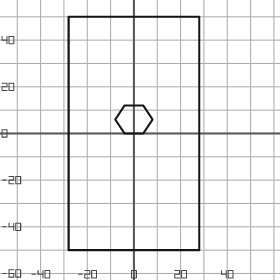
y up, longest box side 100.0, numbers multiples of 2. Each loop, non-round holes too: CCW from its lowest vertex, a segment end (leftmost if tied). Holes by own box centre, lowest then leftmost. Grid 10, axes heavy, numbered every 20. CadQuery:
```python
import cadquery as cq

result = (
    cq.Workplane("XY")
    .moveTo(-28.0, -50.0)
    .lineTo(28.0, -50.0)
    .lineTo(28.0, 50.0)
    .lineTo(-28.0, 50.0)
    .close()
    .moveTo(-4.0, 0.0)
    .lineTo(4.0, 0.0)
    .lineTo(8.0, 6.0)
    .lineTo(4.0, 12.0)
    .lineTo(-4.0, 12.0)
    .lineTo(-8.0, 6.0)
    .close()
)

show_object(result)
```